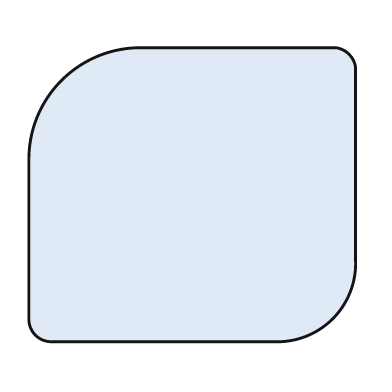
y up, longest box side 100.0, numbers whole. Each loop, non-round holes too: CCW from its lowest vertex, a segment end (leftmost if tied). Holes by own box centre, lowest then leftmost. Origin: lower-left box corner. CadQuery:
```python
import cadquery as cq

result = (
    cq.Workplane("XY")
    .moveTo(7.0, 0.0)
    .lineTo(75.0, 0.0)
    .threePointArc((93.0, 7.0), (100.0, 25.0))
    .lineTo(100.0, 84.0)
    .threePointArc((98.0, 88.0), (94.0, 90.0))
    .lineTo(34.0, 90.0)
    .threePointArc((10.0, 80.0), (0.0, 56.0))
    .lineTo(0.0, 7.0)
    .threePointArc((2.0, 2.0), (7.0, 0.0))
    .close()
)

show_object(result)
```